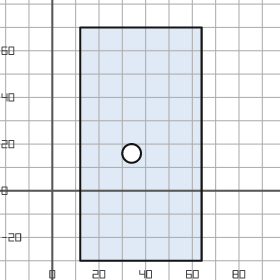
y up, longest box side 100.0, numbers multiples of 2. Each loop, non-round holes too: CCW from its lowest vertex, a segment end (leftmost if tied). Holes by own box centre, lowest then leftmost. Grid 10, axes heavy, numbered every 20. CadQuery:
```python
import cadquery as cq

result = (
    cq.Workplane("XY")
    .moveTo(12.0, -30.0)
    .lineTo(64.0, -30.0)
    .lineTo(64.0, 70.0)
    .lineTo(12.0, 70.0)
    .close()
    .moveTo(34.0, 16.0)
    .circle(4.0)
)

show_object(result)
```